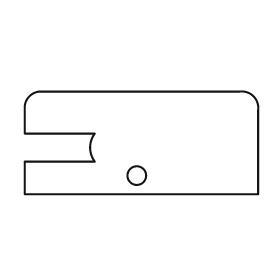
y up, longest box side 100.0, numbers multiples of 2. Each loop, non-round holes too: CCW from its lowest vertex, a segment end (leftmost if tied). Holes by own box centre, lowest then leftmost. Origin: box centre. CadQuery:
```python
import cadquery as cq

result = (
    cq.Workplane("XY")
    .moveTo(-50.0, -22.0)
    .lineTo(50.0, -22.0)
    .lineTo(50.0, 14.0)
    .threePointArc((48.0, 20.0), (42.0, 22.0))
    .lineTo(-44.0, 22.0)
    .threePointArc((-48.0, 20.0), (-50.0, 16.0))
    .lineTo(-50.0, 4.0)
    .lineTo(-20.0, 4.0)
    .threePointArc((-22.0, -2.0), (-20.0, -8.0))
    .lineTo(-50.0, -8.0)
    .close()
    .moveTo(-2.0, -14.0)
    .circle(4.0)
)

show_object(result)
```